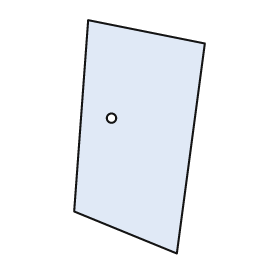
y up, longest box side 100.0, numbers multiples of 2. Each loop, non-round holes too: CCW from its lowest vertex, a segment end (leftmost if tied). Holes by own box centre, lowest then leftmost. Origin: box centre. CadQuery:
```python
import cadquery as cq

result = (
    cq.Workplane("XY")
    .moveTo(16.0, -50.0)
    .lineTo(28.0, 40.0)
    .lineTo(-22.0, 50.0)
    .lineTo(-28.0, -32.0)
    .close()
    .moveTo(-12.0, 8.0)
    .circle(2.0)
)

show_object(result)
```